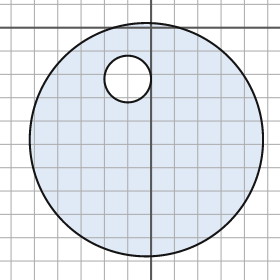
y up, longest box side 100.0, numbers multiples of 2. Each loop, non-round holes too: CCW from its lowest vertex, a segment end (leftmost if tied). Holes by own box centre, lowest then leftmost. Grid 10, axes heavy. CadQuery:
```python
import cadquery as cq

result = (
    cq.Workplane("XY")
    .moveTo(-2.0, -48.0)
    .circle(50.0)
    .moveTo(-10.0, -22.0)
    .circle(10.0)
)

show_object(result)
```